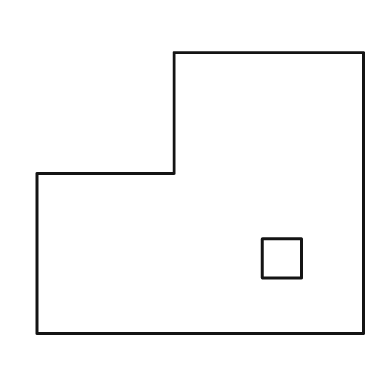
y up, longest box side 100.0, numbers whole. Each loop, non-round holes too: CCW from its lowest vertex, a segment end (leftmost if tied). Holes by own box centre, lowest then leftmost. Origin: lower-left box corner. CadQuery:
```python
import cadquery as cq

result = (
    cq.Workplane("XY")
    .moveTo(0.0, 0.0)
    .lineTo(100.0, 0.0)
    .lineTo(100.0, 86.0)
    .lineTo(42.0, 86.0)
    .lineTo(42.0, 49.0)
    .lineTo(0.0, 49.0)
    .close()
    .moveTo(69.0, 17.0)
    .lineTo(81.0, 17.0)
    .lineTo(81.0, 29.0)
    .lineTo(69.0, 29.0)
    .close()
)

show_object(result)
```